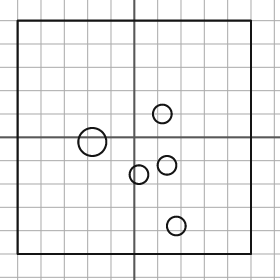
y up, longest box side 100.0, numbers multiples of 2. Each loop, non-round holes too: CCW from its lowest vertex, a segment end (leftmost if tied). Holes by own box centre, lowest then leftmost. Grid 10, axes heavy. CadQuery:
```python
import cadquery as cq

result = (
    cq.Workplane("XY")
    .moveTo(-50.0, -50.0)
    .lineTo(50.0, -50.0)
    .lineTo(50.0, 50.0)
    .lineTo(-50.0, 50.0)
    .close()
    .moveTo(18.0, -38.0)
    .circle(4.0)
    .moveTo(2.0, -16.0)
    .circle(4.0)
    .moveTo(14.0, -12.0)
    .circle(4.0)
    .moveTo(-18.0, -2.0)
    .circle(6.0)
    .moveTo(12.0, 10.0)
    .circle(4.0)
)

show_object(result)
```